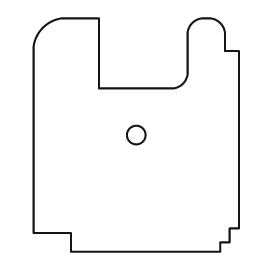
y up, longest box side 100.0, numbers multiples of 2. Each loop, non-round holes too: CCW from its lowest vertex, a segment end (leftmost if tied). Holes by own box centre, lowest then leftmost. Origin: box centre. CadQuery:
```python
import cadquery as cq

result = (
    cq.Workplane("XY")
    .moveTo(-28.0, -50.0)
    .lineTo(36.0, -50.0)
    .lineTo(36.0, -46.0)
    .lineTo(40.0, -46.0)
    .lineTo(40.0, -40.0)
    .lineTo(44.0, -40.0)
    .lineTo(44.0, 36.0)
    .lineTo(38.0, 36.0)
    .lineTo(38.0, 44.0)
    .threePointArc((36.0, 48.0), (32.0, 50.0))
    .lineTo(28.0, 50.0)
    .threePointArc((24.0, 48.0), (22.0, 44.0))
    .lineTo(22.0, 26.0)
    .threePointArc((20.0, 22.0), (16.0, 20.0))
    .lineTo(-16.0, 20.0)
    .lineTo(-16.0, 50.0)
    .lineTo(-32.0, 50.0)
    .threePointArc((-40.0, 46.0), (-44.0, 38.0))
    .lineTo(-44.0, -42.0)
    .lineTo(-28.0, -42.0)
    .close()
    .moveTo(0.0, 0.0)
    .circle(4.0)
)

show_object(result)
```